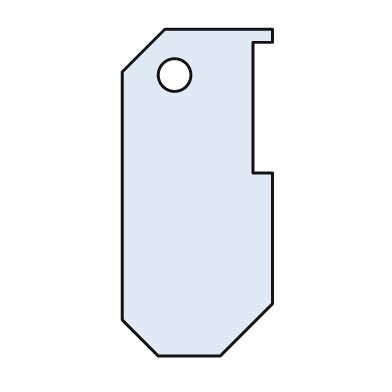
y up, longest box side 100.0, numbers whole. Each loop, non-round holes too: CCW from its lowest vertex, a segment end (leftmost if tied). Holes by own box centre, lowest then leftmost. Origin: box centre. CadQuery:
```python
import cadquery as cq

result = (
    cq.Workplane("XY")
    .moveTo(-12.0, -50.0)
    .lineTo(7.0, -50.0)
    .lineTo(23.0, -34.0)
    .lineTo(23.0, 6.0)
    .lineTo(17.0, 6.0)
    .lineTo(17.0, 46.0)
    .lineTo(23.0, 46.0)
    .lineTo(23.0, 50.0)
    .lineTo(-10.0, 50.0)
    .lineTo(-23.0, 37.0)
    .lineTo(-23.0, -39.0)
    .close()
    .moveTo(-7.0, 36.0)
    .circle(5.0)
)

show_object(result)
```